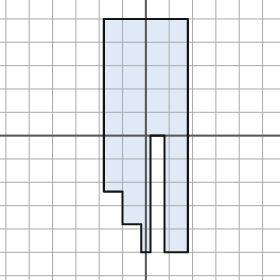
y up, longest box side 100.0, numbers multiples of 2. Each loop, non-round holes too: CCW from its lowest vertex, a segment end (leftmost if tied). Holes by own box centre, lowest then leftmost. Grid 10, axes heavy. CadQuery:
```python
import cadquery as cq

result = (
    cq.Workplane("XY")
    .moveTo(-2.0, -50.0)
    .lineTo(2.0, -50.0)
    .lineTo(2.0, 0.0)
    .lineTo(8.0, 0.0)
    .lineTo(8.0, -50.0)
    .lineTo(18.0, -50.0)
    .lineTo(18.0, 50.0)
    .lineTo(-18.0, 50.0)
    .lineTo(-18.0, -24.0)
    .lineTo(-10.0, -24.0)
    .lineTo(-10.0, -38.0)
    .lineTo(-2.0, -38.0)
    .close()
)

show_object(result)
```